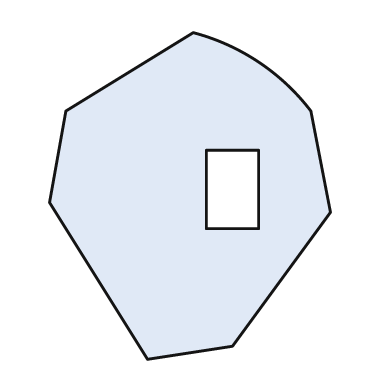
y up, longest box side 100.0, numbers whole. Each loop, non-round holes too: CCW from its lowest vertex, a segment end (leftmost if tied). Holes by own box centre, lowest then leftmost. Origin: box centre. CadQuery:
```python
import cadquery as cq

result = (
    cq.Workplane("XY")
    .moveTo(-13.0, -50.0)
    .lineTo(13.0, -46.0)
    .lineTo(43.0, -5.0)
    .lineTo(37.0, 26.0)
    .threePointArc((21.0, 41.0), (1.0, 50.0))
    .lineTo(-38.0, 26.0)
    .lineTo(-43.0, -2.0)
    .close()
    .moveTo(5.0, -10.0)
    .lineTo(21.0, -10.0)
    .lineTo(21.0, 14.0)
    .lineTo(5.0, 14.0)
    .close()
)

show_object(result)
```